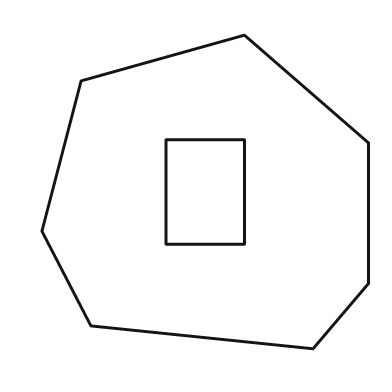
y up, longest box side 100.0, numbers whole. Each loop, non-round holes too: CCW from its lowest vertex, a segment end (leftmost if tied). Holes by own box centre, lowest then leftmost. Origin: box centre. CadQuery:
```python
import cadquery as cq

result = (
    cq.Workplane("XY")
    .moveTo(33.0, -48.0)
    .lineTo(50.0, -28.0)
    .lineTo(50.0, 15.0)
    .lineTo(12.0, 48.0)
    .lineTo(-38.0, 34.0)
    .lineTo(-50.0, -12.0)
    .lineTo(-35.0, -41.0)
    .close()
    .moveTo(-12.0, -16.0)
    .lineTo(12.0, -16.0)
    .lineTo(12.0, 16.0)
    .lineTo(-12.0, 16.0)
    .close()
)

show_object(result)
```